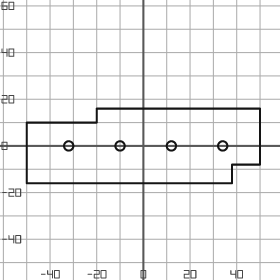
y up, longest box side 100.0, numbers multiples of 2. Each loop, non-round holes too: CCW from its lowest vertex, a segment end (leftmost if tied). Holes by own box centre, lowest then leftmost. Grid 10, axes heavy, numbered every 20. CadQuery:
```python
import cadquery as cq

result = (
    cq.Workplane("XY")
    .moveTo(-50.0, -16.0)
    .lineTo(38.0, -16.0)
    .lineTo(38.0, -8.0)
    .lineTo(50.0, -8.0)
    .lineTo(50.0, 16.0)
    .lineTo(-20.0, 16.0)
    .lineTo(-20.0, 10.0)
    .lineTo(-50.0, 10.0)
    .close()
    .moveTo(-32.0, 0.0)
    .circle(2.0)
    .moveTo(-10.0, 0.0)
    .circle(2.0)
    .moveTo(12.0, 0.0)
    .circle(2.0)
    .moveTo(34.0, 0.0)
    .circle(2.0)
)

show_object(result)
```